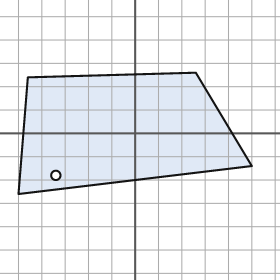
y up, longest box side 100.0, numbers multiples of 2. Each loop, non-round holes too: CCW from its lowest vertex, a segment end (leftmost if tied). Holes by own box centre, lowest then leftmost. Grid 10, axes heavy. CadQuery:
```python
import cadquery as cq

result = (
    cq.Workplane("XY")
    .moveTo(-50.0, -26.0)
    .lineTo(50.0, -14.0)
    .lineTo(26.0, 26.0)
    .lineTo(-46.0, 24.0)
    .close()
    .moveTo(-34.0, -18.0)
    .circle(2.0)
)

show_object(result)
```